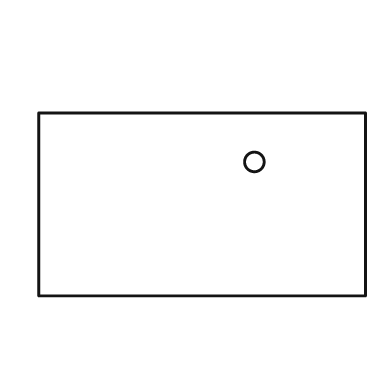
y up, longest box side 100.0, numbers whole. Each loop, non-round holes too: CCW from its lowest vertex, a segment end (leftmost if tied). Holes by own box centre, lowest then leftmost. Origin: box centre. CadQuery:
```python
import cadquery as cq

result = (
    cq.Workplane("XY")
    .moveTo(-50.0, -28.0)
    .lineTo(50.0, -28.0)
    .lineTo(50.0, 28.0)
    .lineTo(-50.0, 28.0)
    .close()
    .moveTo(16.0, 13.0)
    .circle(3.0)
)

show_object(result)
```